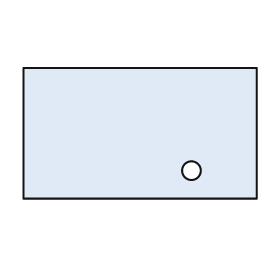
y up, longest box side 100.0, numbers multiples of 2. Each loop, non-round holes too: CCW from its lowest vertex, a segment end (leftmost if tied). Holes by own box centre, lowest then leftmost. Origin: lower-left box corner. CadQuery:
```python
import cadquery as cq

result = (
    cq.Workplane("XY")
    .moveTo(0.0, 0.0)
    .lineTo(100.0, 0.0)
    .lineTo(100.0, 56.0)
    .lineTo(0.0, 56.0)
    .close()
    .moveTo(72.0, 12.0)
    .circle(4.0)
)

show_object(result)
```